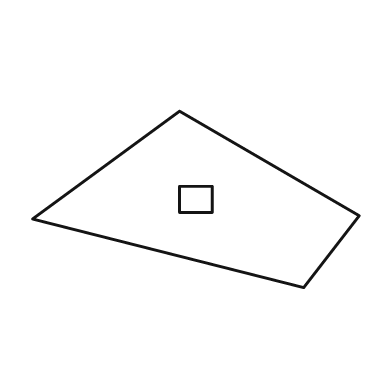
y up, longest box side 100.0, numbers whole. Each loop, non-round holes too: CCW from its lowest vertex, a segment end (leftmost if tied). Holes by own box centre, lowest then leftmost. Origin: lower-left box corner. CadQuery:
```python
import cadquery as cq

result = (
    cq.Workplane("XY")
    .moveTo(83.0, 0.0)
    .lineTo(100.0, 22.0)
    .lineTo(45.0, 54.0)
    .lineTo(0.0, 21.0)
    .close()
    .moveTo(45.0, 23.0)
    .lineTo(55.0, 23.0)
    .lineTo(55.0, 31.0)
    .lineTo(45.0, 31.0)
    .close()
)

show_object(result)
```